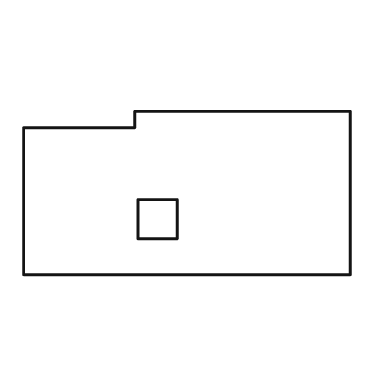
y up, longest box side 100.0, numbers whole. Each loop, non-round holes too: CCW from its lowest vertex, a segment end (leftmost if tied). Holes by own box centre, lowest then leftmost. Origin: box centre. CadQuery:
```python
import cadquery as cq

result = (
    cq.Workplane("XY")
    .moveTo(-50.0, -25.0)
    .lineTo(50.0, -25.0)
    .lineTo(50.0, 25.0)
    .lineTo(-16.0, 25.0)
    .lineTo(-16.0, 20.0)
    .lineTo(-50.0, 20.0)
    .close()
    .moveTo(-15.0, -14.0)
    .lineTo(-3.0, -14.0)
    .lineTo(-3.0, -2.0)
    .lineTo(-15.0, -2.0)
    .close()
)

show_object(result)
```